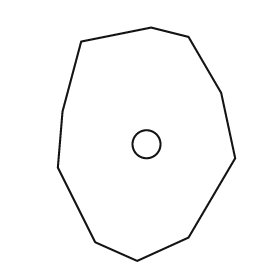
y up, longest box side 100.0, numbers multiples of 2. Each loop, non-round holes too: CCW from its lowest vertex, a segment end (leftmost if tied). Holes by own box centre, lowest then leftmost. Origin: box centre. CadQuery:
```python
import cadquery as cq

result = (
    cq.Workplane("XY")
    .moveTo(-4.0, -50.0)
    .lineTo(18.0, -40.0)
    .lineTo(38.0, -6.0)
    .lineTo(32.0, 22.0)
    .lineTo(18.0, 46.0)
    .lineTo(2.0, 50.0)
    .lineTo(-28.0, 44.0)
    .lineTo(-36.0, 14.0)
    .lineTo(-38.0, -10.0)
    .lineTo(-22.0, -42.0)
    .close()
    .moveTo(0.0, 0.0)
    .circle(6.0)
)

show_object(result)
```